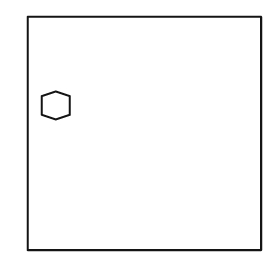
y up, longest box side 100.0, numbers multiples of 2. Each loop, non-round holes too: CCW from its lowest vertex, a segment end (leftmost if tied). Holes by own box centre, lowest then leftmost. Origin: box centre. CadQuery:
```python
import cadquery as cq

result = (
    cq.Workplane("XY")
    .moveTo(-50.0, -50.0)
    .lineTo(50.0, -50.0)
    .lineTo(50.0, 50.0)
    .lineTo(-50.0, 50.0)
    .close()
    .moveTo(-38.0, 6.0)
    .lineTo(-32.0, 8.0)
    .lineTo(-32.0, 16.0)
    .lineTo(-38.0, 18.0)
    .lineTo(-44.0, 16.0)
    .lineTo(-44.0, 8.0)
    .close()
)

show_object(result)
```